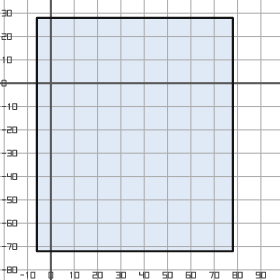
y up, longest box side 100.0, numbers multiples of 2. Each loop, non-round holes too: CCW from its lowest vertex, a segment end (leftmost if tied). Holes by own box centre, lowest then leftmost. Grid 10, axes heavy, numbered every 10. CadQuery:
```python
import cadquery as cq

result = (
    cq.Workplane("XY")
    .moveTo(-6.0, -72.0)
    .lineTo(78.0, -72.0)
    .lineTo(78.0, 28.0)
    .lineTo(-6.0, 28.0)
    .close()
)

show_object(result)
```